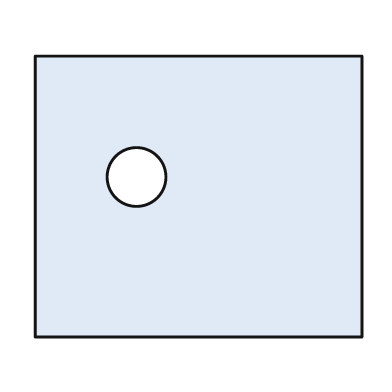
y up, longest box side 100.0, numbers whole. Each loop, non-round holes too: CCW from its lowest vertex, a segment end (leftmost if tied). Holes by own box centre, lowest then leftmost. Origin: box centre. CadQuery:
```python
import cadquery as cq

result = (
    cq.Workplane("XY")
    .moveTo(-50.0, -43.0)
    .lineTo(50.0, -43.0)
    .lineTo(50.0, 43.0)
    .lineTo(-50.0, 43.0)
    .close()
    .moveTo(-19.0, 6.0)
    .circle(9.0)
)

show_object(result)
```